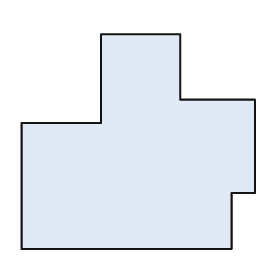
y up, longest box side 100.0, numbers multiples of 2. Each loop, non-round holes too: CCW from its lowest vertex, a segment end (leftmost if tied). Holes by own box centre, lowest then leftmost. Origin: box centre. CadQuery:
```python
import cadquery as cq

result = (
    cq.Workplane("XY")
    .moveTo(-50.0, -46.0)
    .lineTo(40.0, -46.0)
    .lineTo(40.0, -22.0)
    .lineTo(50.0, -22.0)
    .lineTo(50.0, 18.0)
    .lineTo(18.0, 18.0)
    .lineTo(18.0, 46.0)
    .lineTo(-16.0, 46.0)
    .lineTo(-16.0, 8.0)
    .lineTo(-50.0, 8.0)
    .close()
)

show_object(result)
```